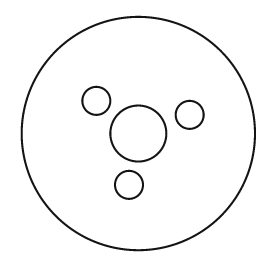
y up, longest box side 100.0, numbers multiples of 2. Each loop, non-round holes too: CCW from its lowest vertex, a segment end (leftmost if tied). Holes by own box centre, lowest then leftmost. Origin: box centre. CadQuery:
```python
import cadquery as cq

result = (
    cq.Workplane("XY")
    .moveTo(0.0, 0.0)
    .circle(50.0)
    .moveTo(-4.0, -22.0)
    .circle(6.0)
    .moveTo(0.0, 0.0)
    .circle(12.0)
    .moveTo(22.0, 8.0)
    .circle(6.0)
    .moveTo(-18.0, 14.0)
    .circle(6.0)
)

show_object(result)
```